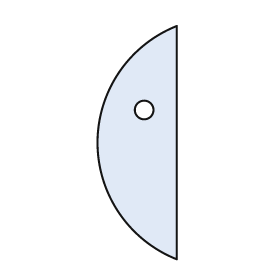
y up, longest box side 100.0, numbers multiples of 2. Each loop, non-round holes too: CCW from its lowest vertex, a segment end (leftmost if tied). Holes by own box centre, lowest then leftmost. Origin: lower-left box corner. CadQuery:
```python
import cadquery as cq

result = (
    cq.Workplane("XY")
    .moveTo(34.0, 0.0)
    .lineTo(34.0, 100.0)
    .threePointArc((0.0, 50.0), (34.0, 0.0))
    .close()
    .moveTo(20.0, 64.0)
    .circle(4.0)
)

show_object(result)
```